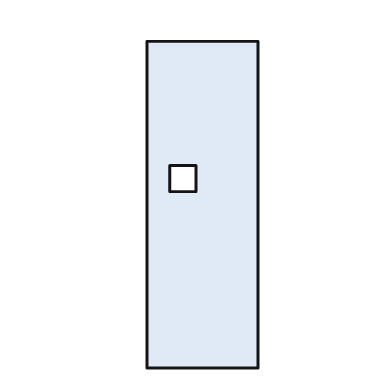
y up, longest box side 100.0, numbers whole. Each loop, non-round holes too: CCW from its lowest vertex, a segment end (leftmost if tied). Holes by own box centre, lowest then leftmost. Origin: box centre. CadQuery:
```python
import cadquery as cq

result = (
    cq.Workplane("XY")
    .moveTo(-17.0, -50.0)
    .lineTo(17.0, -50.0)
    .lineTo(17.0, 50.0)
    .lineTo(-17.0, 50.0)
    .close()
    .moveTo(-10.0, 4.0)
    .lineTo(-2.0, 4.0)
    .lineTo(-2.0, 12.0)
    .lineTo(-10.0, 12.0)
    .close()
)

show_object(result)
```